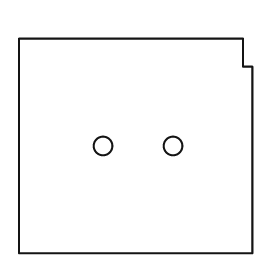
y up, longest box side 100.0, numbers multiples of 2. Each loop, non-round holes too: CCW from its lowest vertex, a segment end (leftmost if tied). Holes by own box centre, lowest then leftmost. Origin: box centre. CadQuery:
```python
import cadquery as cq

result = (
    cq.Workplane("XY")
    .moveTo(-50.0, -46.0)
    .lineTo(50.0, -46.0)
    .lineTo(50.0, 34.0)
    .lineTo(46.0, 34.0)
    .lineTo(46.0, 46.0)
    .lineTo(-50.0, 46.0)
    .close()
    .moveTo(-14.0, 0.0)
    .circle(4.0)
    .moveTo(16.0, 0.0)
    .circle(4.0)
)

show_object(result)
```